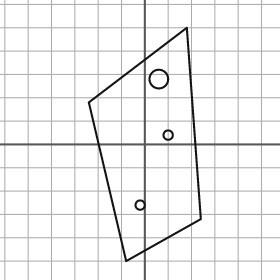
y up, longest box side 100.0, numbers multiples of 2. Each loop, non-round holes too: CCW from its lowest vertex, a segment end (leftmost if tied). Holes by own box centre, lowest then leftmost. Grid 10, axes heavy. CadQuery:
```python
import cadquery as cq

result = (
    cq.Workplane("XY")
    .moveTo(-8.0, -50.0)
    .lineTo(24.0, -32.0)
    .lineTo(18.0, 50.0)
    .lineTo(-24.0, 18.0)
    .close()
    .moveTo(-2.0, -26.0)
    .circle(2.0)
    .moveTo(10.0, 4.0)
    .circle(2.0)
    .moveTo(6.0, 28.0)
    .circle(4.0)
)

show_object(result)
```